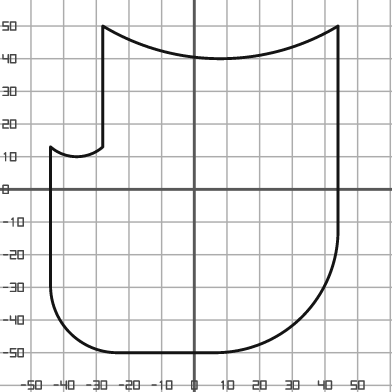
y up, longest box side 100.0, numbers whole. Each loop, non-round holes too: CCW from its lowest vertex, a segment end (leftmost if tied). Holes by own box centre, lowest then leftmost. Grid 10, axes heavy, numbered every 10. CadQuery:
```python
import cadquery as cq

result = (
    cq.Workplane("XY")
    .moveTo(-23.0, -50.0)
    .lineTo(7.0, -50.0)
    .threePointArc((33.0, -39.0), (44.0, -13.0))
    .lineTo(44.0, 50.0)
    .threePointArc((8.0, 40.0), (-28.0, 50.0))
    .lineTo(-28.0, 13.0)
    .threePointArc((-36.0, 10.0), (-44.0, 13.0))
    .lineTo(-44.0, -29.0)
    .threePointArc((-38.0, -44.0), (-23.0, -50.0))
    .close()
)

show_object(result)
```